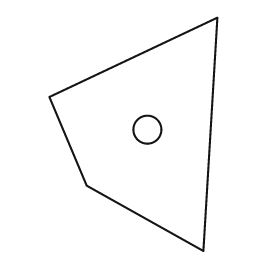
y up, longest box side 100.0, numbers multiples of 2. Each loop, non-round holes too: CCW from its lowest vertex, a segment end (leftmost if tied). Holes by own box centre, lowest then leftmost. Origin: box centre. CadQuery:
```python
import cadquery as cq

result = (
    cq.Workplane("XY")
    .moveTo(30.0, -50.0)
    .lineTo(36.0, 50.0)
    .lineTo(-36.0, 16.0)
    .lineTo(-20.0, -22.0)
    .close()
    .moveTo(6.0, 2.0)
    .circle(6.0)
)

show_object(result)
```